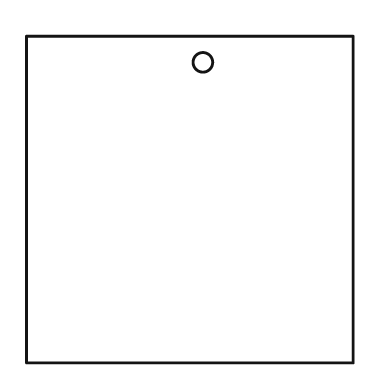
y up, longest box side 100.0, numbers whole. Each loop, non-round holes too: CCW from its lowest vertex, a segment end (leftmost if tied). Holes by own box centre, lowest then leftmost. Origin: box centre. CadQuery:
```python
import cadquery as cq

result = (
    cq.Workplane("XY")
    .moveTo(-50.0, -50.0)
    .lineTo(50.0, -50.0)
    .lineTo(50.0, 50.0)
    .lineTo(-50.0, 50.0)
    .close()
    .moveTo(4.0, 42.0)
    .circle(3.0)
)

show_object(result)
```